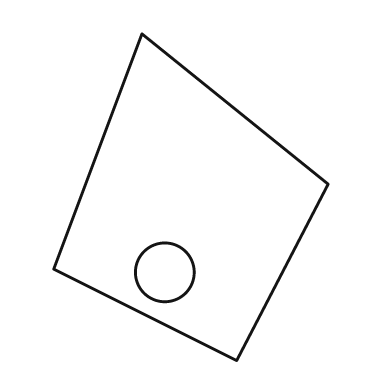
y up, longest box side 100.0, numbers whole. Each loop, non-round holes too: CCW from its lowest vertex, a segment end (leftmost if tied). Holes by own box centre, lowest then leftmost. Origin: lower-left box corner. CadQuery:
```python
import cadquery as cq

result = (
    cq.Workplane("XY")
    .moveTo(56.0, 0.0)
    .lineTo(84.0, 54.0)
    .lineTo(27.0, 100.0)
    .lineTo(0.0, 28.0)
    .close()
    .moveTo(34.0, 27.0)
    .circle(9.0)
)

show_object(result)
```